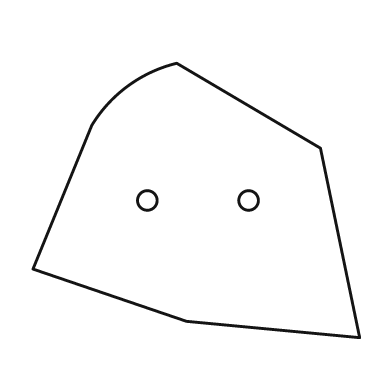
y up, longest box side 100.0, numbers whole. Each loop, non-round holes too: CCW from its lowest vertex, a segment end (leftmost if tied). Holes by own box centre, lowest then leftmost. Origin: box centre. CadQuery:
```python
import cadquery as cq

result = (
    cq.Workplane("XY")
    .moveTo(50.0, -42.0)
    .lineTo(38.0, 16.0)
    .lineTo(-6.0, 42.0)
    .threePointArc((-21.0, 35.0), (-32.0, 23.0))
    .lineTo(-50.0, -21.0)
    .lineTo(-3.0, -37.0)
    .close()
    .moveTo(-15.0, 0.0)
    .circle(3.0)
    .moveTo(16.0, 0.0)
    .circle(3.0)
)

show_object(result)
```